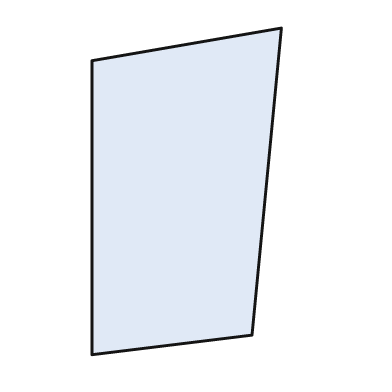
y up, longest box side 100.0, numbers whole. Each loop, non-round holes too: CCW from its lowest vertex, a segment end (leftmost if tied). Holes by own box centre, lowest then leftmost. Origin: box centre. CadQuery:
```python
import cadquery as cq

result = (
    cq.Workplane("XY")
    .moveTo(-29.0, -50.0)
    .lineTo(20.0, -44.0)
    .lineTo(29.0, 50.0)
    .lineTo(-29.0, 40.0)
    .close()
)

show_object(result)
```